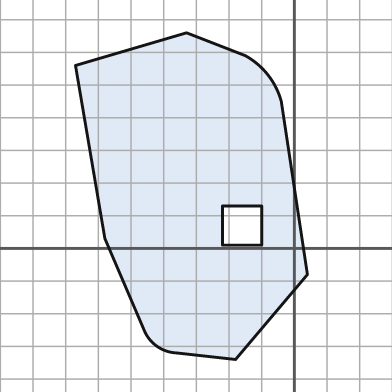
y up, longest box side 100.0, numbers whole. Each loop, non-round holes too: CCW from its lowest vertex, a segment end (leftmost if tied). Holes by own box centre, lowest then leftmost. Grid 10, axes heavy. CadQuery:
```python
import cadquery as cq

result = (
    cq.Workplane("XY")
    .moveTo(-18.0, -34.0)
    .lineTo(4.0, -8.0)
    .lineTo(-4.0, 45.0)
    .threePointArc((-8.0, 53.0), (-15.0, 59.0))
    .lineTo(-33.0, 66.0)
    .lineTo(-67.0, 56.0)
    .lineTo(-58.0, 3.0)
    .lineTo(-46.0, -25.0)
    .threePointArc((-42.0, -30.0), (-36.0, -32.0))
    .close()
    .moveTo(-22.0, 1.0)
    .lineTo(-10.0, 1.0)
    .lineTo(-10.0, 13.0)
    .lineTo(-22.0, 13.0)
    .close()
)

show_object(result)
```